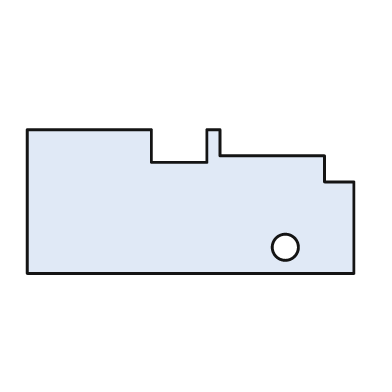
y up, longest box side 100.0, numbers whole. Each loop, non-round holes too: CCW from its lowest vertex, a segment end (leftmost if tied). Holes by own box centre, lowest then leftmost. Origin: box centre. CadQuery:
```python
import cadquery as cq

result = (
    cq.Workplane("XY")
    .moveTo(-50.0, -22.0)
    .lineTo(50.0, -22.0)
    .lineTo(50.0, 6.0)
    .lineTo(41.0, 6.0)
    .lineTo(41.0, 14.0)
    .lineTo(9.0, 14.0)
    .lineTo(9.0, 22.0)
    .lineTo(5.0, 22.0)
    .lineTo(5.0, 12.0)
    .lineTo(-12.0, 12.0)
    .lineTo(-12.0, 22.0)
    .lineTo(-50.0, 22.0)
    .close()
    .moveTo(29.0, -14.0)
    .circle(4.0)
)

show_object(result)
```